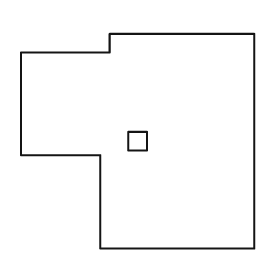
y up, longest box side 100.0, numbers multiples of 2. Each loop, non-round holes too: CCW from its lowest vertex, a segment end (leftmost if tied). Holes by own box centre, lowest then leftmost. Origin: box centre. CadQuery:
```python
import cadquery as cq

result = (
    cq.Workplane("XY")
    .moveTo(-16.0, -46.0)
    .lineTo(50.0, -46.0)
    .lineTo(50.0, 46.0)
    .lineTo(-12.0, 46.0)
    .lineTo(-12.0, 38.0)
    .lineTo(-50.0, 38.0)
    .lineTo(-50.0, -6.0)
    .lineTo(-16.0, -6.0)
    .close()
    .moveTo(-4.0, -4.0)
    .lineTo(4.0, -4.0)
    .lineTo(4.0, 4.0)
    .lineTo(-4.0, 4.0)
    .close()
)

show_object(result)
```